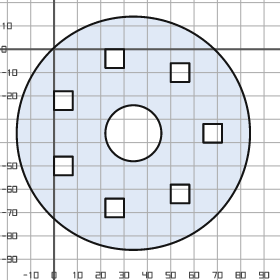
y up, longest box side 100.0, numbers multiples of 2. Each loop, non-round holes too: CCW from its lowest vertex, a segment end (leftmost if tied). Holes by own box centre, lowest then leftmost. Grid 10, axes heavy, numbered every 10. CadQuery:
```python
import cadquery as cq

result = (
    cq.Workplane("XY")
    .moveTo(34.0, -36.0)
    .circle(50.0)
    .moveTo(22.0, -72.0)
    .lineTo(30.0, -72.0)
    .lineTo(30.0, -64.0)
    .lineTo(22.0, -64.0)
    .close()
    .moveTo(50.0, -66.0)
    .lineTo(58.0, -66.0)
    .lineTo(58.0, -58.0)
    .lineTo(50.0, -58.0)
    .close()
    .moveTo(0.0, -54.0)
    .lineTo(8.0, -54.0)
    .lineTo(8.0, -46.0)
    .lineTo(0.0, -46.0)
    .close()
    .moveTo(34.0, -36.0)
    .circle(12.0)
    .moveTo(64.0, -40.0)
    .lineTo(72.0, -40.0)
    .lineTo(72.0, -32.0)
    .lineTo(64.0, -32.0)
    .close()
    .moveTo(0.0, -26.0)
    .lineTo(8.0, -26.0)
    .lineTo(8.0, -18.0)
    .lineTo(0.0, -18.0)
    .close()
    .moveTo(50.0, -14.0)
    .lineTo(58.0, -14.0)
    .lineTo(58.0, -6.0)
    .lineTo(50.0, -6.0)
    .close()
    .moveTo(22.0, -8.0)
    .lineTo(30.0, -8.0)
    .lineTo(30.0, 0.0)
    .lineTo(22.0, 0.0)
    .close()
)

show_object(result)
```